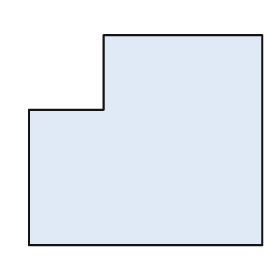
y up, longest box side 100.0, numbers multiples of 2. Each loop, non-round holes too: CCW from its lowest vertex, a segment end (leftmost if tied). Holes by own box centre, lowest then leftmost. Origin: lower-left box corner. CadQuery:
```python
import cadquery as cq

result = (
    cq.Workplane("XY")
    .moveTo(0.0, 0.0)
    .lineTo(100.0, 0.0)
    .lineTo(100.0, 90.0)
    .lineTo(32.0, 90.0)
    .lineTo(32.0, 58.0)
    .lineTo(0.0, 58.0)
    .close()
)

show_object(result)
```